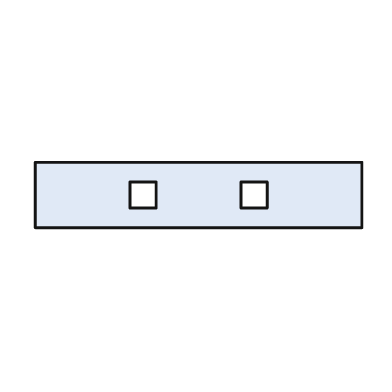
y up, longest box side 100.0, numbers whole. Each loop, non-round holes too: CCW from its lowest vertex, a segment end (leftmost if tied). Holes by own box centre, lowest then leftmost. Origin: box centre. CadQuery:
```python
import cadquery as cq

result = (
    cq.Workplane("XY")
    .moveTo(-50.0, -10.0)
    .lineTo(50.0, -10.0)
    .lineTo(50.0, 10.0)
    .lineTo(-50.0, 10.0)
    .close()
    .moveTo(-21.0, -4.0)
    .lineTo(-13.0, -4.0)
    .lineTo(-13.0, 4.0)
    .lineTo(-21.0, 4.0)
    .close()
    .moveTo(13.0, -4.0)
    .lineTo(21.0, -4.0)
    .lineTo(21.0, 4.0)
    .lineTo(13.0, 4.0)
    .close()
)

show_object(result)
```